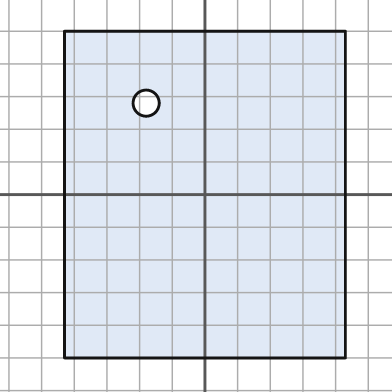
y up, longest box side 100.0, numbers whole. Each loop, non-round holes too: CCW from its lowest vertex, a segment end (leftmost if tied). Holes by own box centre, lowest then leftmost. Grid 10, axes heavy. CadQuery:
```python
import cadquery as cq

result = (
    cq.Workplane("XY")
    .moveTo(-43.0, -50.0)
    .lineTo(43.0, -50.0)
    .lineTo(43.0, 50.0)
    .lineTo(-43.0, 50.0)
    .close()
    .moveTo(-18.0, 28.0)
    .circle(4.0)
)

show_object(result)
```